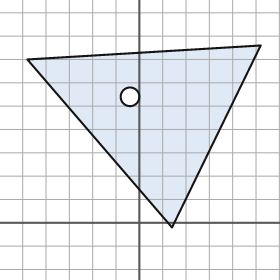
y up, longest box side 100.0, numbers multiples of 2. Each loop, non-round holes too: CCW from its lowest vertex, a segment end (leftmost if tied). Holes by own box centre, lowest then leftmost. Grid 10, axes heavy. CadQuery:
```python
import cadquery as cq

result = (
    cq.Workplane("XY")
    .moveTo(14.0, -2.0)
    .lineTo(52.0, 76.0)
    .lineTo(-48.0, 70.0)
    .close()
    .moveTo(-4.0, 54.0)
    .circle(4.0)
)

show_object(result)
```